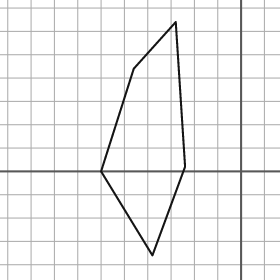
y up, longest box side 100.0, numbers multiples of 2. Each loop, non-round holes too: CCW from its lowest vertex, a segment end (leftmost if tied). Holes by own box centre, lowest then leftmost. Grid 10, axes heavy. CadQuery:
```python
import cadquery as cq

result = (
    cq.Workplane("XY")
    .moveTo(-38.0, -36.0)
    .lineTo(-24.0, 2.0)
    .lineTo(-28.0, 64.0)
    .lineTo(-46.0, 44.0)
    .lineTo(-60.0, 0.0)
    .close()
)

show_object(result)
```